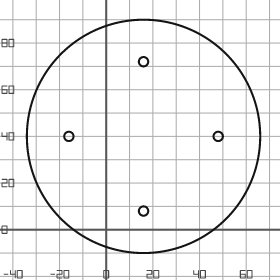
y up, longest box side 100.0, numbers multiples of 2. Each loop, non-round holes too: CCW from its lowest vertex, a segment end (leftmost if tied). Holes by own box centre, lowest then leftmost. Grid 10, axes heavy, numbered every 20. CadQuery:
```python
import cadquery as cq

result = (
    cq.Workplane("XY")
    .moveTo(16.0, 40.0)
    .circle(50.0)
    .moveTo(16.0, 8.0)
    .circle(2.0)
    .moveTo(-16.0, 40.0)
    .circle(2.0)
    .moveTo(48.0, 40.0)
    .circle(2.0)
    .moveTo(16.0, 72.0)
    .circle(2.0)
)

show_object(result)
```